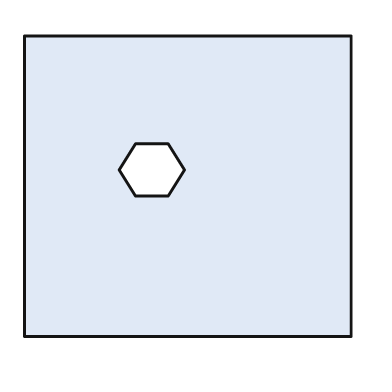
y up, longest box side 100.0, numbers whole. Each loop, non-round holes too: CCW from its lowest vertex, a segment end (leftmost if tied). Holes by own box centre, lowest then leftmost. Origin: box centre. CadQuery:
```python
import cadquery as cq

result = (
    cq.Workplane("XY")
    .moveTo(-50.0, -46.0)
    .lineTo(50.0, -46.0)
    .lineTo(50.0, 46.0)
    .lineTo(-50.0, 46.0)
    .close()
    .moveTo(-16.0, -3.0)
    .lineTo(-6.0, -3.0)
    .lineTo(-1.0, 5.0)
    .lineTo(-6.0, 13.0)
    .lineTo(-16.0, 13.0)
    .lineTo(-21.0, 5.0)
    .close()
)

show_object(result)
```